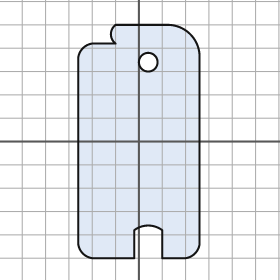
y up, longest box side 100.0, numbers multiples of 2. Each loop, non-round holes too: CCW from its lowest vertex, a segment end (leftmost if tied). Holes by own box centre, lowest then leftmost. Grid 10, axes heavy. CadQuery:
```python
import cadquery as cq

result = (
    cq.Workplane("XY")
    .moveTo(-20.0, -50.0)
    .lineTo(-2.0, -50.0)
    .lineTo(-2.0, -38.0)
    .threePointArc((4.0, -36.0), (10.0, -38.0))
    .lineTo(10.0, -50.0)
    .lineTo(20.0, -50.0)
    .threePointArc((24.0, -48.0), (26.0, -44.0))
    .lineTo(26.0, 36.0)
    .threePointArc((22.0, 46.0), (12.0, 50.0))
    .lineTo(-10.0, 50.0)
    .threePointArc((-12.0, 46.0), (-10.0, 42.0))
    .lineTo(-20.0, 42.0)
    .threePointArc((-24.0, 40.0), (-26.0, 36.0))
    .lineTo(-26.0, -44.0)
    .threePointArc((-24.0, -48.0), (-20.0, -50.0))
    .close()
    .moveTo(4.0, 34.0)
    .circle(4.0)
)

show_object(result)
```